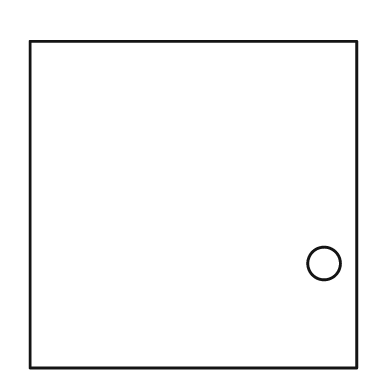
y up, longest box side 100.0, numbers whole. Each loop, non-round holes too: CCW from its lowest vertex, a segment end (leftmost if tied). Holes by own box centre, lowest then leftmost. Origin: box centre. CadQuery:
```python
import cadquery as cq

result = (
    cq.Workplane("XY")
    .moveTo(-50.0, -50.0)
    .lineTo(50.0, -50.0)
    .lineTo(50.0, 50.0)
    .lineTo(-50.0, 50.0)
    .close()
    .moveTo(40.0, -18.0)
    .circle(5.0)
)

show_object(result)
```